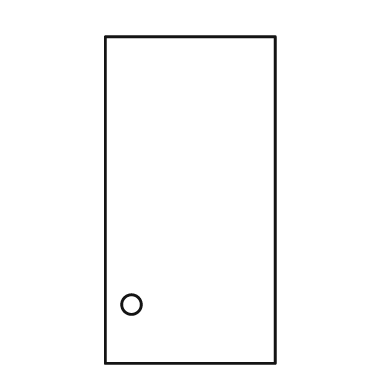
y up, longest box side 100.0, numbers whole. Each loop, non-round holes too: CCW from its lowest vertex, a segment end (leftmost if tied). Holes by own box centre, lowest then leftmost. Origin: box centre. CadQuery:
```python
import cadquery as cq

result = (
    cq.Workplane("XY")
    .moveTo(-26.0, -50.0)
    .lineTo(26.0, -50.0)
    .lineTo(26.0, 50.0)
    .lineTo(-26.0, 50.0)
    .close()
    .moveTo(-18.0, -32.0)
    .circle(3.0)
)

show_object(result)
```